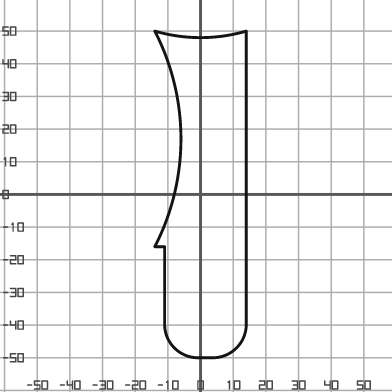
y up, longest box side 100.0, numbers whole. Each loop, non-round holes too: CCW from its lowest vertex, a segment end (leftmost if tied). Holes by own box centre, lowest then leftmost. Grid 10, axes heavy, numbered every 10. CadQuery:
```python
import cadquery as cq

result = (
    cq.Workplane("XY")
    .moveTo(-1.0, -50.0)
    .lineTo(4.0, -50.0)
    .threePointArc((11.0, -47.0), (14.0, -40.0))
    .lineTo(14.0, 50.0)
    .threePointArc((0.0, 48.0), (-14.0, 50.0))
    .threePointArc((-6.0, 17.0), (-14.0, -16.0))
    .lineTo(-11.0, -16.0)
    .lineTo(-11.0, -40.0)
    .threePointArc((-8.0, -47.0), (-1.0, -50.0))
    .close()
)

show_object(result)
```